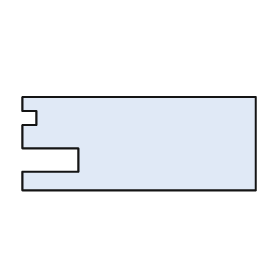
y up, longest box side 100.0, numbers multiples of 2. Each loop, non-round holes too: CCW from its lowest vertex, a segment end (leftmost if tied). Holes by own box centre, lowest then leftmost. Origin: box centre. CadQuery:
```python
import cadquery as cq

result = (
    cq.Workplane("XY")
    .moveTo(-50.0, -20.0)
    .lineTo(50.0, -20.0)
    .lineTo(50.0, 20.0)
    .lineTo(-50.0, 20.0)
    .lineTo(-50.0, 14.0)
    .lineTo(-44.0, 14.0)
    .lineTo(-44.0, 8.0)
    .lineTo(-50.0, 8.0)
    .lineTo(-50.0, -2.0)
    .lineTo(-26.0, -2.0)
    .lineTo(-26.0, -12.0)
    .lineTo(-50.0, -12.0)
    .close()
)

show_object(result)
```